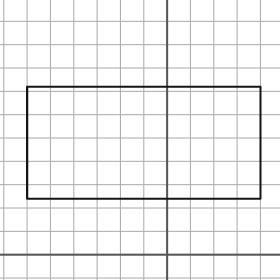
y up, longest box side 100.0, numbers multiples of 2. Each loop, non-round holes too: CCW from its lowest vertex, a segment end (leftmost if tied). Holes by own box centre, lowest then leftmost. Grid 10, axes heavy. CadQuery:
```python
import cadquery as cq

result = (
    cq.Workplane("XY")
    .moveTo(-60.0, 24.0)
    .lineTo(40.0, 24.0)
    .lineTo(40.0, 72.0)
    .lineTo(-60.0, 72.0)
    .close()
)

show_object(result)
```